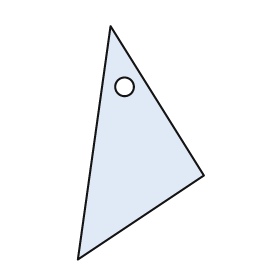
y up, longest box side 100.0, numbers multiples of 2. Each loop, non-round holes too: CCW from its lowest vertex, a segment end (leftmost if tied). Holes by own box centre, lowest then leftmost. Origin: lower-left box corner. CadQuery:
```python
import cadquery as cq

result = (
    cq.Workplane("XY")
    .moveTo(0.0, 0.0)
    .lineTo(54.0, 36.0)
    .lineTo(14.0, 100.0)
    .close()
    .moveTo(20.0, 74.0)
    .circle(4.0)
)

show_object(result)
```